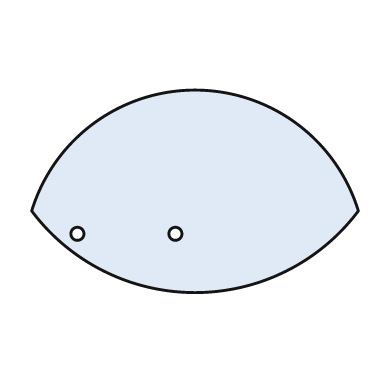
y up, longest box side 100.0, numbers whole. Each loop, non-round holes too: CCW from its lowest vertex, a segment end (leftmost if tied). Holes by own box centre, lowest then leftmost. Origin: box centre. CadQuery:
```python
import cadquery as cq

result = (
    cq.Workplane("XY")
    .moveTo(-50.0, -6.0)
    .threePointArc((0.0, -31.0), (50.0, -6.0))
    .threePointArc((0.0, 31.0), (-50.0, -6.0))
    .close()
    .moveTo(-36.0, -13.0)
    .circle(2.0)
    .moveTo(-6.0, -13.0)
    .circle(2.0)
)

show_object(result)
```